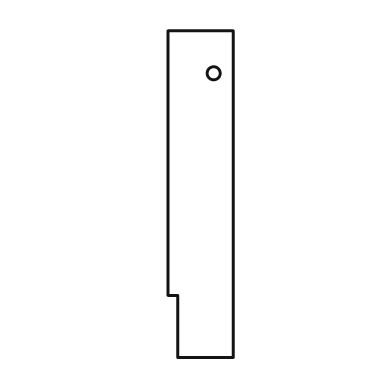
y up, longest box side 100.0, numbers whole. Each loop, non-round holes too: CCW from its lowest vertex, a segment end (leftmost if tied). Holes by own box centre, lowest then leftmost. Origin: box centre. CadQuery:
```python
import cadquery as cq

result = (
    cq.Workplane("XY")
    .moveTo(-7.0, -50.0)
    .lineTo(10.0, -50.0)
    .lineTo(10.0, 50.0)
    .lineTo(-10.0, 50.0)
    .lineTo(-10.0, -31.0)
    .lineTo(-7.0, -31.0)
    .close()
    .moveTo(4.0, 37.0)
    .circle(2.0)
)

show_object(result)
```